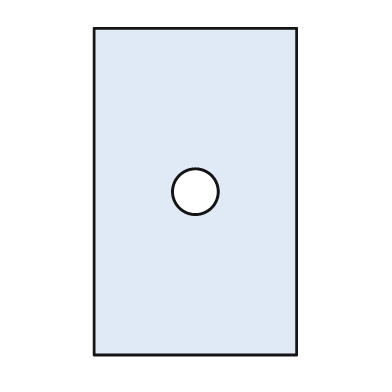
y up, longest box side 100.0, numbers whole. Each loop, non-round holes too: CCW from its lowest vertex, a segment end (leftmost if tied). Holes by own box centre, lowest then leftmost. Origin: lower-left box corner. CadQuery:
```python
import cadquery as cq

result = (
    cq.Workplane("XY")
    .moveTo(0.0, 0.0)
    .lineTo(62.0, 0.0)
    .lineTo(62.0, 100.0)
    .lineTo(0.0, 100.0)
    .close()
    .moveTo(31.0, 50.0)
    .circle(7.0)
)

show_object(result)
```